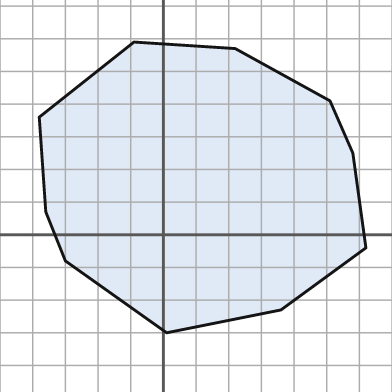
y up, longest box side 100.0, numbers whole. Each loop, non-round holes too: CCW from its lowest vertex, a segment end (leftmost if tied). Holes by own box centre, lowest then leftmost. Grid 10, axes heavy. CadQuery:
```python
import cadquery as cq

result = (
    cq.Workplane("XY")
    .moveTo(1.0, -30.0)
    .lineTo(36.0, -23.0)
    .lineTo(62.0, -4.0)
    .lineTo(58.0, 25.0)
    .lineTo(51.0, 41.0)
    .lineTo(22.0, 57.0)
    .lineTo(-9.0, 59.0)
    .lineTo(-38.0, 36.0)
    .lineTo(-36.0, 7.0)
    .lineTo(-30.0, -8.0)
    .close()
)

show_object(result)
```